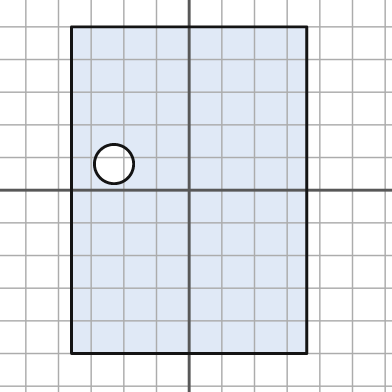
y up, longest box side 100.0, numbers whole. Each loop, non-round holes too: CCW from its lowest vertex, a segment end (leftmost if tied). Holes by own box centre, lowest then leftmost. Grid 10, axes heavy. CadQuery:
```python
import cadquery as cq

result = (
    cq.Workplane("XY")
    .moveTo(-36.0, -50.0)
    .lineTo(36.0, -50.0)
    .lineTo(36.0, 50.0)
    .lineTo(-36.0, 50.0)
    .close()
    .moveTo(-23.0, 8.0)
    .circle(6.0)
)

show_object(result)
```